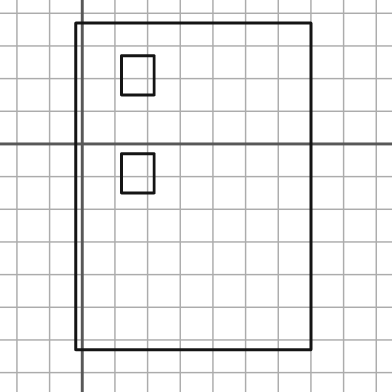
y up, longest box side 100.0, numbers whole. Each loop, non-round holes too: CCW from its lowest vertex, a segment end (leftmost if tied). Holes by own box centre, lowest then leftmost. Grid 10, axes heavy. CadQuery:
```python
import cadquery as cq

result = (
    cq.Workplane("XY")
    .moveTo(-2.0, -63.0)
    .lineTo(70.0, -63.0)
    .lineTo(70.0, 37.0)
    .lineTo(-2.0, 37.0)
    .close()
    .moveTo(12.0, -15.0)
    .lineTo(22.0, -15.0)
    .lineTo(22.0, -3.0)
    .lineTo(12.0, -3.0)
    .close()
    .moveTo(12.0, 15.0)
    .lineTo(22.0, 15.0)
    .lineTo(22.0, 27.0)
    .lineTo(12.0, 27.0)
    .close()
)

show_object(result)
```